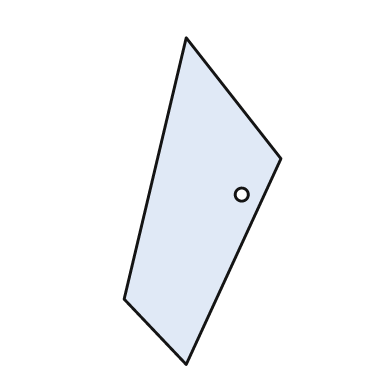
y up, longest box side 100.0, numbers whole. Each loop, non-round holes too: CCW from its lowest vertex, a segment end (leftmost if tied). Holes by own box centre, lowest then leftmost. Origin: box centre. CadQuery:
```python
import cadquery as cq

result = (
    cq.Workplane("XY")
    .moveTo(-5.0, -50.0)
    .lineTo(24.0, 13.0)
    .lineTo(-5.0, 50.0)
    .lineTo(-24.0, -30.0)
    .close()
    .moveTo(12.0, 2.0)
    .circle(2.0)
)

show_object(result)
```